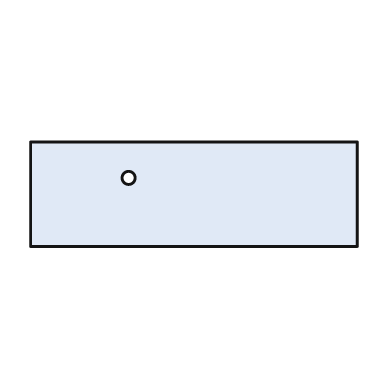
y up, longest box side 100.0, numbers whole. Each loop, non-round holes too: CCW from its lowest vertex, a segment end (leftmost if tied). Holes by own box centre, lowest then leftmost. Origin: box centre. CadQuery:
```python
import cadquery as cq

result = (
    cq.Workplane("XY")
    .moveTo(-50.0, -16.0)
    .lineTo(50.0, -16.0)
    .lineTo(50.0, 16.0)
    .lineTo(-50.0, 16.0)
    .close()
    .moveTo(-20.0, 5.0)
    .circle(2.0)
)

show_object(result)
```